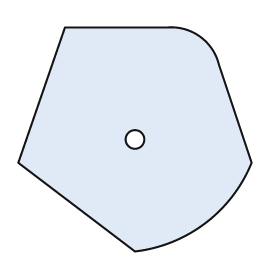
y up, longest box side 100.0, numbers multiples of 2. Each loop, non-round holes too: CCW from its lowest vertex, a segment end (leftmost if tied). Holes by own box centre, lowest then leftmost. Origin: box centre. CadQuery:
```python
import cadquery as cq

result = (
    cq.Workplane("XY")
    .moveTo(0.0, -48.0)
    .threePointArc((30.0, -36.0), (50.0, -10.0))
    .lineTo(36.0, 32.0)
    .threePointArc((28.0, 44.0), (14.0, 48.0))
    .lineTo(-30.0, 48.0)
    .lineTo(-50.0, -10.0)
    .close()
    .moveTo(0.0, 0.0)
    .circle(4.0)
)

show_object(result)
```